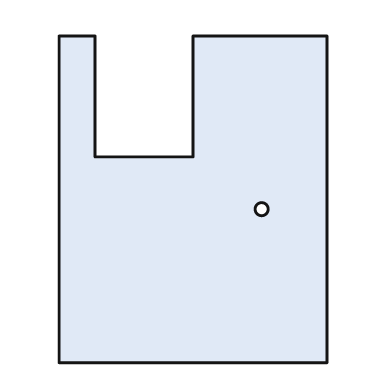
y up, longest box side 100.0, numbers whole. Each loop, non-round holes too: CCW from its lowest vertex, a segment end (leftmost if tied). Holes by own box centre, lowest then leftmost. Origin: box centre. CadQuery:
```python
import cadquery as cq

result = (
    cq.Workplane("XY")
    .moveTo(-41.0, -50.0)
    .lineTo(41.0, -50.0)
    .lineTo(41.0, 50.0)
    .lineTo(0.0, 50.0)
    .lineTo(0.0, 13.0)
    .lineTo(-30.0, 13.0)
    .lineTo(-30.0, 50.0)
    .lineTo(-41.0, 50.0)
    .close()
    .moveTo(21.0, -3.0)
    .circle(2.0)
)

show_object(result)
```